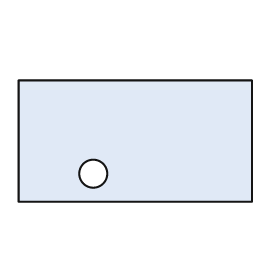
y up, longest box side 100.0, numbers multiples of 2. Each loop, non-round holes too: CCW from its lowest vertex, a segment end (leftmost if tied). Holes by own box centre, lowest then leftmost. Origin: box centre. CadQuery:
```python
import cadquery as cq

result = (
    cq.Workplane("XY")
    .moveTo(-50.0, -26.0)
    .lineTo(50.0, -26.0)
    .lineTo(50.0, 26.0)
    .lineTo(-50.0, 26.0)
    .close()
    .moveTo(-18.0, -14.0)
    .circle(6.0)
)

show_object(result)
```